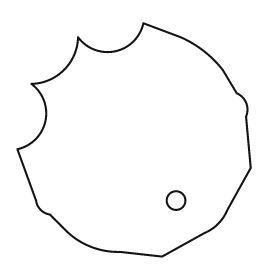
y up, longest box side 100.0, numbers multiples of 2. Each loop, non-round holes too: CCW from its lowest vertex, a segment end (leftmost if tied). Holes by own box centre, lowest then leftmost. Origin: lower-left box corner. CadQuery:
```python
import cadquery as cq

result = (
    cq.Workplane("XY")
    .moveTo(62.0, 0.0)
    .lineTo(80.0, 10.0)
    .threePointArc((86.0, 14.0), (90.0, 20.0))
    .lineTo(100.0, 38.0)
    .lineTo(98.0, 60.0)
    .threePointArc((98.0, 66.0), (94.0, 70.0))
    .lineTo(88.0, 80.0)
    .threePointArc((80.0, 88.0), (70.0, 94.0))
    .lineTo(54.0, 100.0)
    .threePointArc((42.0, 88.0), (26.0, 94.0))
    .threePointArc((20.0, 80.0), (6.0, 74.0))
    .threePointArc((12.0, 58.0), (0.0, 46.0))
    .lineTo(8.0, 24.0)
    .threePointArc((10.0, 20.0), (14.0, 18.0))
    .lineTo(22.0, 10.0)
    .threePointArc((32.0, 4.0), (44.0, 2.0))
    .close()
    .moveTo(68.0, 24.0)
    .circle(4.0)
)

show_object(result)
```